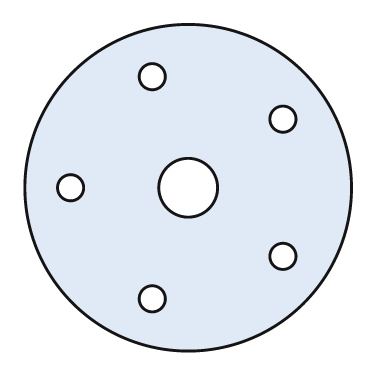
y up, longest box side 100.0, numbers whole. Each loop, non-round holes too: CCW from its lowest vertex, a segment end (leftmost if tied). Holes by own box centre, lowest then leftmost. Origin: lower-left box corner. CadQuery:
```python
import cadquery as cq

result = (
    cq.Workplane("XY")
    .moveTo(50.0, 50.0)
    .circle(50.0)
    .moveTo(39.0, 16.0)
    .circle(4.0)
    .moveTo(79.0, 29.0)
    .circle(4.0)
    .moveTo(14.0, 50.0)
    .circle(4.0)
    .moveTo(50.0, 50.0)
    .circle(9.0)
    .moveTo(79.0, 71.0)
    .circle(4.0)
    .moveTo(39.0, 84.0)
    .circle(4.0)
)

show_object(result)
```